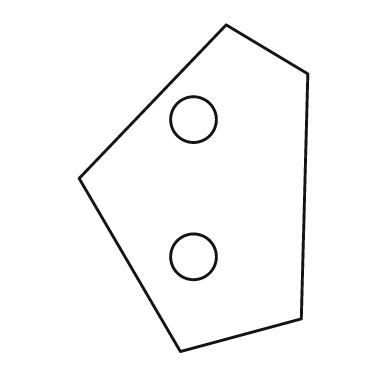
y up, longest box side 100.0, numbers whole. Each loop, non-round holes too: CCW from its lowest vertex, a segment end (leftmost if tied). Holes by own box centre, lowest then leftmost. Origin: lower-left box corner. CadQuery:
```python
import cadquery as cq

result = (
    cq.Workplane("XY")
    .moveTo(31.0, 0.0)
    .lineTo(68.0, 10.0)
    .lineTo(70.0, 85.0)
    .lineTo(45.0, 100.0)
    .lineTo(0.0, 53.0)
    .close()
    .moveTo(35.0, 29.0)
    .circle(7.0)
    .moveTo(35.0, 71.0)
    .circle(7.0)
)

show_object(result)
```